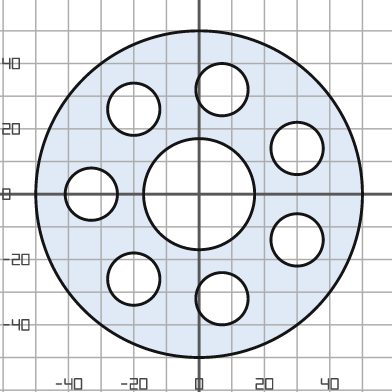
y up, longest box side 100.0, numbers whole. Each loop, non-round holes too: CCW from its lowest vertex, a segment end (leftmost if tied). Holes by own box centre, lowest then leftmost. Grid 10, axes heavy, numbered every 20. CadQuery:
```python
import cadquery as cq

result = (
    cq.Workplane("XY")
    .moveTo(0.0, 0.0)
    .circle(50.0)
    .moveTo(7.0, -32.0)
    .circle(8.0)
    .moveTo(-20.0, -26.0)
    .circle(8.0)
    .moveTo(30.0, -14.0)
    .circle(8.0)
    .moveTo(-33.0, 0.0)
    .circle(8.0)
    .moveTo(0.0, 0.0)
    .circle(17.0)
    .moveTo(30.0, 14.0)
    .circle(8.0)
    .moveTo(-20.0, 26.0)
    .circle(8.0)
    .moveTo(7.0, 32.0)
    .circle(8.0)
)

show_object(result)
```